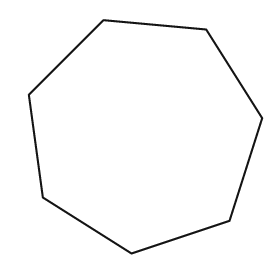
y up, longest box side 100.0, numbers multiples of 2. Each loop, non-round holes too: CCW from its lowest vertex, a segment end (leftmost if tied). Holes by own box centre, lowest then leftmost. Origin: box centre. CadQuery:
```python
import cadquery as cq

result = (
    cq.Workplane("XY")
    .moveTo(-6.0, -50.0)
    .lineTo(36.0, -36.0)
    .lineTo(50.0, 8.0)
    .lineTo(26.0, 46.0)
    .lineTo(-18.0, 50.0)
    .lineTo(-50.0, 18.0)
    .lineTo(-44.0, -26.0)
    .close()
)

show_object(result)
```